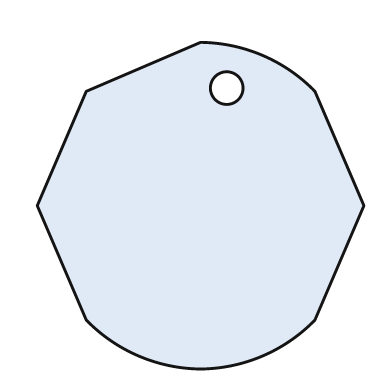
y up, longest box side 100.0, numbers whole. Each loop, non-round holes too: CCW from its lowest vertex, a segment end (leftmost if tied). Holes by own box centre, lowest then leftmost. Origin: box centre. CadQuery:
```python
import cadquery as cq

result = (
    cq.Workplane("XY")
    .moveTo(0.0, -50.0)
    .threePointArc((19.0, -46.0), (35.0, -35.0))
    .lineTo(50.0, 0.0)
    .lineTo(35.0, 35.0)
    .threePointArc((19.0, 46.0), (0.0, 50.0))
    .lineTo(-35.0, 35.0)
    .lineTo(-50.0, 0.0)
    .lineTo(-35.0, -35.0)
    .threePointArc((-19.0, -46.0), (0.0, -50.0))
    .close()
    .moveTo(8.0, 36.0)
    .circle(5.0)
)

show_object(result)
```